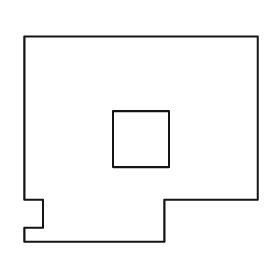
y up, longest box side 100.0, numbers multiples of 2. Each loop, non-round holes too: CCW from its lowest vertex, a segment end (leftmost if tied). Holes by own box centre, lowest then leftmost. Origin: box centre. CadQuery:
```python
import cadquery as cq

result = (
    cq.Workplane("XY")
    .moveTo(-50.0, -44.0)
    .lineTo(10.0, -44.0)
    .lineTo(10.0, -26.0)
    .lineTo(50.0, -26.0)
    .lineTo(50.0, 44.0)
    .lineTo(-50.0, 44.0)
    .lineTo(-50.0, -26.0)
    .lineTo(-42.0, -26.0)
    .lineTo(-42.0, -38.0)
    .lineTo(-50.0, -38.0)
    .close()
    .moveTo(-12.0, -12.0)
    .lineTo(12.0, -12.0)
    .lineTo(12.0, 12.0)
    .lineTo(-12.0, 12.0)
    .close()
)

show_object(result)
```